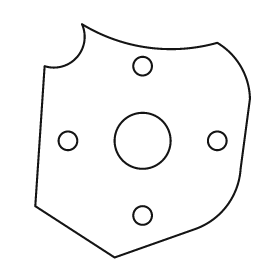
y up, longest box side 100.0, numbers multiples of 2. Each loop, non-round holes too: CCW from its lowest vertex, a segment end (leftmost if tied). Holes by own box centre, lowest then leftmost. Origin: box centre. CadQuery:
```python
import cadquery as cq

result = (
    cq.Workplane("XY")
    .moveTo(-12.0, -50.0)
    .lineTo(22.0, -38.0)
    .threePointArc((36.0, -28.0), (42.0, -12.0))
    .lineTo(46.0, 18.0)
    .threePointArc((42.0, 32.0), (32.0, 42.0))
    .threePointArc((2.0, 40.0), (-26.0, 50.0))
    .threePointArc((-28.0, 36.0), (-42.0, 32.0))
    .lineTo(-46.0, -28.0)
    .close()
    .moveTo(0.0, -32.0)
    .circle(4.0)
    .moveTo(-32.0, 0.0)
    .circle(4.0)
    .moveTo(0.0, 0.0)
    .circle(12.0)
    .moveTo(32.0, 0.0)
    .circle(4.0)
    .moveTo(0.0, 32.0)
    .circle(4.0)
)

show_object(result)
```